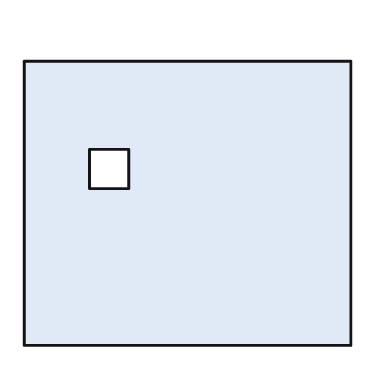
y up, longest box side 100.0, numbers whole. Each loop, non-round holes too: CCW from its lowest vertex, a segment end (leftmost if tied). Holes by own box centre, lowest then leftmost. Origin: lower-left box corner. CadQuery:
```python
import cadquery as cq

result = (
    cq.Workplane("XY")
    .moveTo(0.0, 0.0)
    .lineTo(100.0, 0.0)
    .lineTo(100.0, 87.0)
    .lineTo(0.0, 87.0)
    .close()
    .moveTo(20.0, 48.0)
    .lineTo(32.0, 48.0)
    .lineTo(32.0, 60.0)
    .lineTo(20.0, 60.0)
    .close()
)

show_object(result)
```